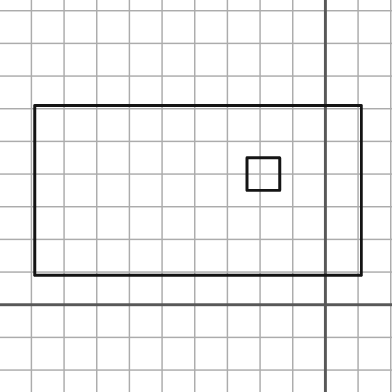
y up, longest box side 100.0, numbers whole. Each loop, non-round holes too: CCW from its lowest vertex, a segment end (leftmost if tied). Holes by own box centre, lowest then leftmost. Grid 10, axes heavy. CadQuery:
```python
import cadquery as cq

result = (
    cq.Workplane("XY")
    .moveTo(-89.0, 9.0)
    .lineTo(11.0, 9.0)
    .lineTo(11.0, 61.0)
    .lineTo(-89.0, 61.0)
    .close()
    .moveTo(-24.0, 35.0)
    .lineTo(-14.0, 35.0)
    .lineTo(-14.0, 45.0)
    .lineTo(-24.0, 45.0)
    .close()
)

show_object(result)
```